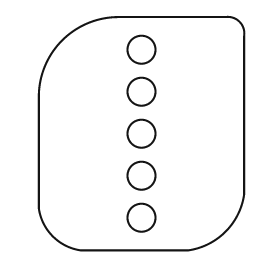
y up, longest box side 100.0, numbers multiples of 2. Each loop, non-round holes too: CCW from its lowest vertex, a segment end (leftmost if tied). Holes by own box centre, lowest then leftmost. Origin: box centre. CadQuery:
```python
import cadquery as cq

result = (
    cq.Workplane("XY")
    .moveTo(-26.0, -50.0)
    .lineTo(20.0, -50.0)
    .threePointArc((36.0, -42.0), (44.0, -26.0))
    .lineTo(44.0, 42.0)
    .threePointArc((42.0, 48.0), (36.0, 50.0))
    .lineTo(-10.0, 50.0)
    .threePointArc((-34.0, 40.0), (-44.0, 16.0))
    .lineTo(-44.0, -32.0)
    .threePointArc((-38.0, -44.0), (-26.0, -50.0))
    .close()
    .moveTo(0.0, -36.0)
    .circle(6.0)
    .moveTo(0.0, -18.0)
    .circle(6.0)
    .moveTo(0.0, 0.0)
    .circle(6.0)
    .moveTo(0.0, 18.0)
    .circle(6.0)
    .moveTo(0.0, 36.0)
    .circle(6.0)
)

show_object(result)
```